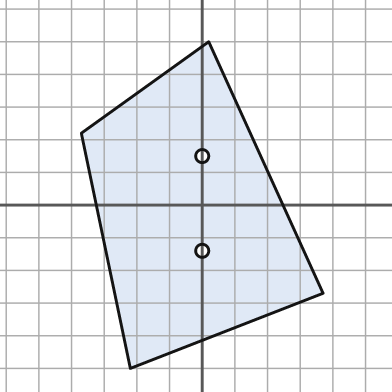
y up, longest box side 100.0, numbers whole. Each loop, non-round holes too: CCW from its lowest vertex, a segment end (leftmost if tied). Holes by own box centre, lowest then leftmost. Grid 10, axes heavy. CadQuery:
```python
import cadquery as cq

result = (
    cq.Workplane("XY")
    .moveTo(-22.0, -50.0)
    .lineTo(37.0, -27.0)
    .lineTo(2.0, 50.0)
    .lineTo(-37.0, 22.0)
    .close()
    .moveTo(0.0, -14.0)
    .circle(2.0)
    .moveTo(0.0, 15.0)
    .circle(2.0)
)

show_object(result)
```